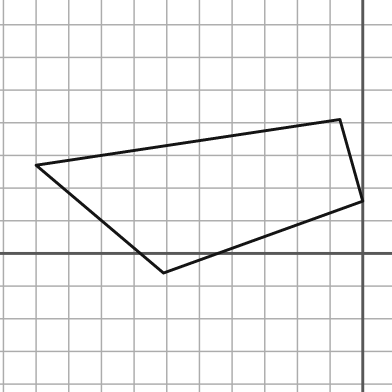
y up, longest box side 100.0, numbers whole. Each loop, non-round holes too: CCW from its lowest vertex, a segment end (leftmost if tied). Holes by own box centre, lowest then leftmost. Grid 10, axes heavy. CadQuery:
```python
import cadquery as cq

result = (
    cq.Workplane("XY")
    .moveTo(-61.0, -6.0)
    .lineTo(0.0, 16.0)
    .lineTo(-7.0, 41.0)
    .lineTo(-100.0, 27.0)
    .close()
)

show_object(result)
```